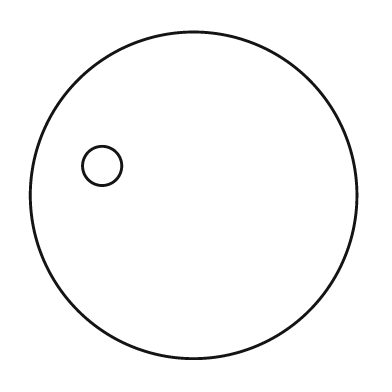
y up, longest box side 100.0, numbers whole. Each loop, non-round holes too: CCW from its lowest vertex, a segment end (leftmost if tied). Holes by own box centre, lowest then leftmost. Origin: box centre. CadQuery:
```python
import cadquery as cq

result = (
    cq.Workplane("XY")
    .moveTo(0.0, 0.0)
    .circle(50.0)
    .moveTo(-28.0, 9.0)
    .circle(6.0)
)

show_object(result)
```